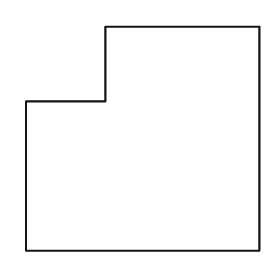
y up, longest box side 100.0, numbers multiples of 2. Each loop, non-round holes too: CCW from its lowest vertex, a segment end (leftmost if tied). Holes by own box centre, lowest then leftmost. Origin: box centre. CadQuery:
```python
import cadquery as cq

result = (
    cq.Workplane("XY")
    .moveTo(-50.0, -48.0)
    .lineTo(50.0, -48.0)
    .lineTo(50.0, 48.0)
    .lineTo(-16.0, 48.0)
    .lineTo(-16.0, 16.0)
    .lineTo(-50.0, 16.0)
    .close()
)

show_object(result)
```